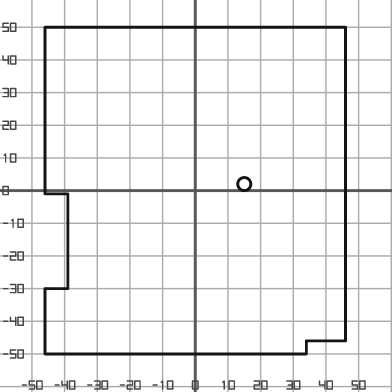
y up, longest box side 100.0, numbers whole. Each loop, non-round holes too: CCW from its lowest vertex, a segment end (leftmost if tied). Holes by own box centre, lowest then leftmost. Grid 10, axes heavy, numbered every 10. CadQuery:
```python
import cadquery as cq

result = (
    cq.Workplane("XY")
    .moveTo(-46.0, -50.0)
    .lineTo(34.0, -50.0)
    .lineTo(34.0, -46.0)
    .lineTo(46.0, -46.0)
    .lineTo(46.0, 50.0)
    .lineTo(-46.0, 50.0)
    .lineTo(-46.0, -1.0)
    .lineTo(-39.0, -1.0)
    .lineTo(-39.0, -30.0)
    .lineTo(-46.0, -30.0)
    .close()
    .moveTo(15.0, 2.0)
    .circle(2.0)
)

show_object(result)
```